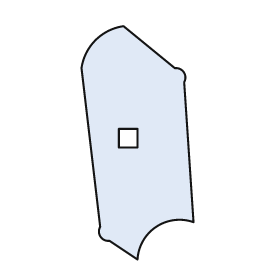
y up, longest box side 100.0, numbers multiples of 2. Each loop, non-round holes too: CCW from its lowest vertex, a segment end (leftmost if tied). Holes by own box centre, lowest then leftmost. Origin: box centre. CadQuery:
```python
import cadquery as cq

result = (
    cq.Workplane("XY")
    .moveTo(0.0, -50.0)
    .threePointArc((8.0, -36.0), (24.0, -34.0))
    .lineTo(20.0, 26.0)
    .threePointArc((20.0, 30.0), (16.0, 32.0))
    .lineTo(-6.0, 50.0)
    .threePointArc((-18.0, 44.0), (-24.0, 32.0))
    .lineTo(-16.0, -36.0)
    .threePointArc((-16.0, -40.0), (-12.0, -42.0))
    .close()
    .moveTo(-8.0, -2.0)
    .lineTo(0.0, -2.0)
    .lineTo(0.0, 6.0)
    .lineTo(-8.0, 6.0)
    .close()
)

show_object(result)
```